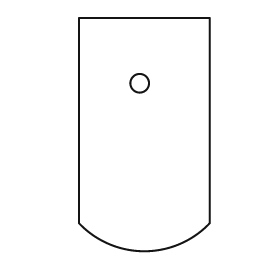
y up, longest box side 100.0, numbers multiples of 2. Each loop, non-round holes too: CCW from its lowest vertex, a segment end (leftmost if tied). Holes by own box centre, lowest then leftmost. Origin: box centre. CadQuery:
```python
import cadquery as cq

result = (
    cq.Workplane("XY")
    .moveTo(-28.0, -38.0)
    .threePointArc((0.0, -50.0), (28.0, -38.0))
    .lineTo(28.0, 50.0)
    .lineTo(-28.0, 50.0)
    .close()
    .moveTo(-2.0, 22.0)
    .circle(4.0)
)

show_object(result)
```